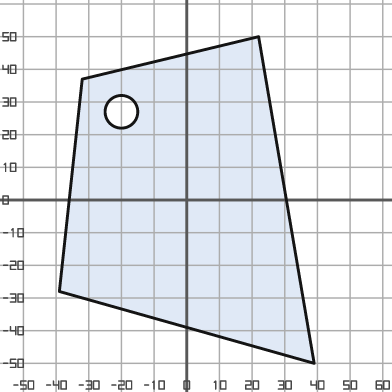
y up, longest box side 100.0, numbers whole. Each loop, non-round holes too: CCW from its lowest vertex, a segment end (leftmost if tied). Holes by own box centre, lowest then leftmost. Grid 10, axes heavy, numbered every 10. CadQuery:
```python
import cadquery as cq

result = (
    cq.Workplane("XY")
    .moveTo(39.0, -50.0)
    .lineTo(22.0, 50.0)
    .lineTo(-32.0, 37.0)
    .lineTo(-39.0, -28.0)
    .close()
    .moveTo(-20.0, 27.0)
    .circle(5.0)
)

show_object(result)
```